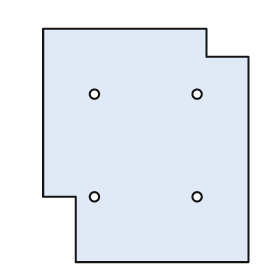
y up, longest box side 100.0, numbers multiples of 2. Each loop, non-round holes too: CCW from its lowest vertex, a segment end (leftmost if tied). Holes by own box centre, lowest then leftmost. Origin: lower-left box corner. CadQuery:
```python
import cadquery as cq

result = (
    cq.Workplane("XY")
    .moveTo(14.0, 0.0)
    .lineTo(88.0, 0.0)
    .lineTo(88.0, 88.0)
    .lineTo(70.0, 88.0)
    .lineTo(70.0, 100.0)
    .lineTo(0.0, 100.0)
    .lineTo(0.0, 28.0)
    .lineTo(14.0, 28.0)
    .close()
    .moveTo(22.0, 28.0)
    .circle(2.0)
    .moveTo(66.0, 28.0)
    .circle(2.0)
    .moveTo(22.0, 72.0)
    .circle(2.0)
    .moveTo(66.0, 72.0)
    .circle(2.0)
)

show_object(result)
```